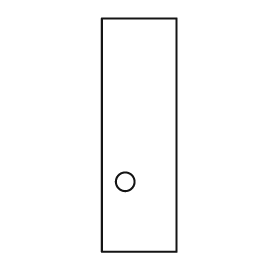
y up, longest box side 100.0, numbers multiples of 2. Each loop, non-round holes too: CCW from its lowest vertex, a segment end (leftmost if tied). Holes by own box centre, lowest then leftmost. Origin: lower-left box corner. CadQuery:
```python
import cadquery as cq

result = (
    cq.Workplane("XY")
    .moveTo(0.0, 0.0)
    .lineTo(32.0, 0.0)
    .lineTo(32.0, 100.0)
    .lineTo(0.0, 100.0)
    .close()
    .moveTo(10.0, 30.0)
    .circle(4.0)
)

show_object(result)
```